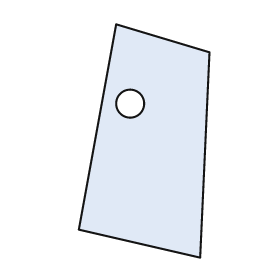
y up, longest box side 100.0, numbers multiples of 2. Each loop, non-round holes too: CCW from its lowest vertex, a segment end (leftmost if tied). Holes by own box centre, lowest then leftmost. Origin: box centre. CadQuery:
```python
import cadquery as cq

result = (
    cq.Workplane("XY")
    .moveTo(24.0, -50.0)
    .lineTo(28.0, 38.0)
    .lineTo(-12.0, 50.0)
    .lineTo(-28.0, -38.0)
    .close()
    .moveTo(-6.0, 16.0)
    .circle(6.0)
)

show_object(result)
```